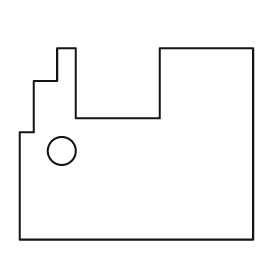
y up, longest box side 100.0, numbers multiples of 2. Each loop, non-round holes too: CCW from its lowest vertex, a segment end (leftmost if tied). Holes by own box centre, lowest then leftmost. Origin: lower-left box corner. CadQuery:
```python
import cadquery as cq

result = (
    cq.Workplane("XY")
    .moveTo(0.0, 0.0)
    .lineTo(100.0, 0.0)
    .lineTo(100.0, 82.0)
    .lineTo(60.0, 82.0)
    .lineTo(60.0, 52.0)
    .lineTo(24.0, 52.0)
    .lineTo(24.0, 82.0)
    .lineTo(16.0, 82.0)
    .lineTo(16.0, 68.0)
    .lineTo(6.0, 68.0)
    .lineTo(6.0, 46.0)
    .lineTo(0.0, 46.0)
    .close()
    .moveTo(18.0, 38.0)
    .circle(6.0)
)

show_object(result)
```